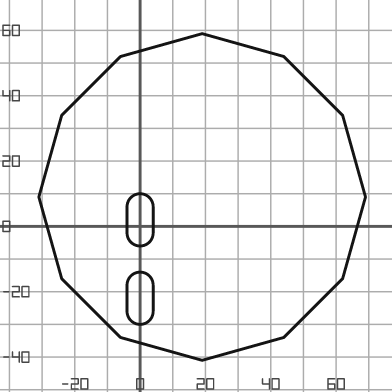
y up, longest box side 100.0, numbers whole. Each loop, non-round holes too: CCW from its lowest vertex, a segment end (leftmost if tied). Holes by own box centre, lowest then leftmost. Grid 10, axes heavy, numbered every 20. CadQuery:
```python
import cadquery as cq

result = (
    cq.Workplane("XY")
    .moveTo(19.0, -41.0)
    .lineTo(44.0, -34.0)
    .lineTo(62.0, -16.0)
    .lineTo(69.0, 9.0)
    .lineTo(62.0, 34.0)
    .lineTo(44.0, 52.0)
    .lineTo(19.0, 59.0)
    .lineTo(-6.0, 52.0)
    .lineTo(-24.0, 34.0)
    .lineTo(-31.0, 9.0)
    .lineTo(-24.0, -16.0)
    .lineTo(-6.0, -34.0)
    .close()
    .moveTo(-4.0, -26.0)
    .threePointArc((0.0, -30.0), (4.0, -26.0))
    .lineTo(4.0, -18.0)
    .threePointArc((0.0, -14.0), (-4.0, -18.0))
    .close()
    .moveTo(-4.0, -2.0)
    .threePointArc((0.0, -6.0), (4.0, -2.0))
    .lineTo(4.0, 6.0)
    .threePointArc((0.0, 10.0), (-4.0, 6.0))
    .close()
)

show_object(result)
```